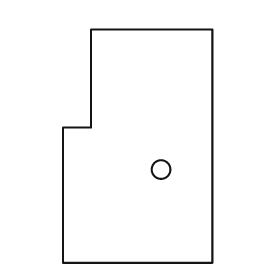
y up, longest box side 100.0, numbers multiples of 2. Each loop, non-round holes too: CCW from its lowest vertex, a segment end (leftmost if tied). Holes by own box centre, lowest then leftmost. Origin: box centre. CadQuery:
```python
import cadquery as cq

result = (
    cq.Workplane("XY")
    .moveTo(-32.0, -50.0)
    .lineTo(32.0, -50.0)
    .lineTo(32.0, 50.0)
    .lineTo(-20.0, 50.0)
    .lineTo(-20.0, 8.0)
    .lineTo(-32.0, 8.0)
    .close()
    .moveTo(10.0, -10.0)
    .circle(4.0)
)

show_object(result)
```